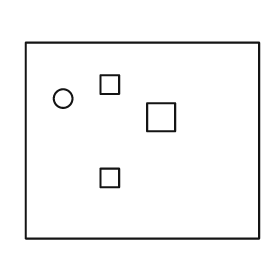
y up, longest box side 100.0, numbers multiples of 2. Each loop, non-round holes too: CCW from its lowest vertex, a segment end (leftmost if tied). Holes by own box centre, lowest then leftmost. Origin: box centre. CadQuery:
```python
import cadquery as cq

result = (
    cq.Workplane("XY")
    .moveTo(-50.0, -42.0)
    .lineTo(50.0, -42.0)
    .lineTo(50.0, 42.0)
    .lineTo(-50.0, 42.0)
    .close()
    .moveTo(-18.0, -20.0)
    .lineTo(-10.0, -20.0)
    .lineTo(-10.0, -12.0)
    .lineTo(-18.0, -12.0)
    .close()
    .moveTo(2.0, 4.0)
    .lineTo(14.0, 4.0)
    .lineTo(14.0, 16.0)
    .lineTo(2.0, 16.0)
    .close()
    .moveTo(-34.0, 18.0)
    .circle(4.0)
    .moveTo(-18.0, 20.0)
    .lineTo(-10.0, 20.0)
    .lineTo(-10.0, 28.0)
    .lineTo(-18.0, 28.0)
    .close()
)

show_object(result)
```